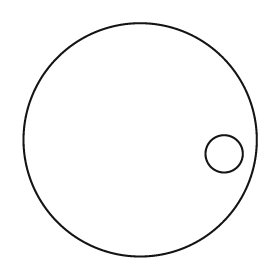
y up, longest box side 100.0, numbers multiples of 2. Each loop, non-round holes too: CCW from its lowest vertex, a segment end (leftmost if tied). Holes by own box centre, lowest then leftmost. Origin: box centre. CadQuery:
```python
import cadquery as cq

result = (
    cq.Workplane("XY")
    .moveTo(0.0, 0.0)
    .circle(50.0)
    .moveTo(36.0, -6.0)
    .circle(8.0)
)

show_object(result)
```